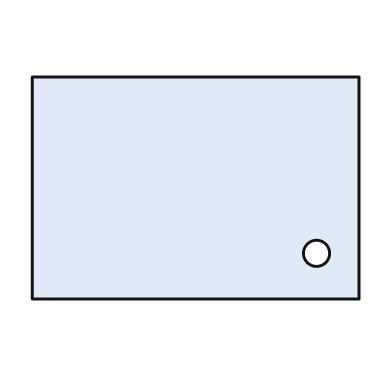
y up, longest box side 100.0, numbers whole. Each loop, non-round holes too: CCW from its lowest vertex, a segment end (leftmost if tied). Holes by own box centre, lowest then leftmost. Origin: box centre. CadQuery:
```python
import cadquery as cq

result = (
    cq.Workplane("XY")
    .moveTo(-50.0, -34.0)
    .lineTo(50.0, -34.0)
    .lineTo(50.0, 34.0)
    .lineTo(-50.0, 34.0)
    .close()
    .moveTo(37.0, -20.0)
    .circle(4.0)
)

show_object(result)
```